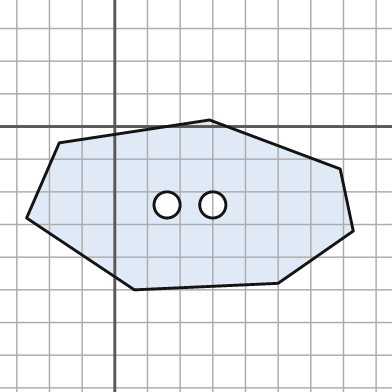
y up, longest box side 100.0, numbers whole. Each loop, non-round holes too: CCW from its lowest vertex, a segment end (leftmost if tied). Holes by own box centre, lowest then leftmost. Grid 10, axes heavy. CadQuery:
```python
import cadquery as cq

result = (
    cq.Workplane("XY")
    .moveTo(6.0, -50.0)
    .lineTo(50.0, -48.0)
    .lineTo(73.0, -32.0)
    .lineTo(69.0, -13.0)
    .lineTo(29.0, 2.0)
    .lineTo(-17.0, -5.0)
    .lineTo(-27.0, -28.0)
    .close()
    .moveTo(16.0, -24.0)
    .circle(4.0)
    .moveTo(30.0, -24.0)
    .circle(4.0)
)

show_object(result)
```